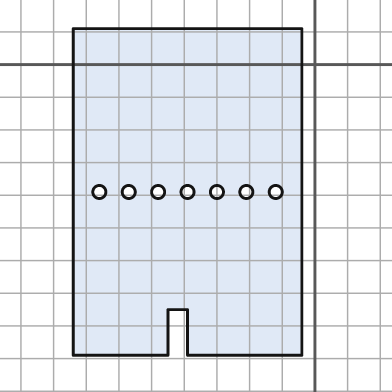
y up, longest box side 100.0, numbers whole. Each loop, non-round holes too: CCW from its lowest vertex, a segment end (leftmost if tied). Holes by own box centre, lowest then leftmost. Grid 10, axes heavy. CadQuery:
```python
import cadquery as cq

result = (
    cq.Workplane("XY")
    .moveTo(-74.0, -89.0)
    .lineTo(-45.0, -89.0)
    .lineTo(-45.0, -75.0)
    .lineTo(-39.0, -75.0)
    .lineTo(-39.0, -89.0)
    .lineTo(-4.0, -89.0)
    .lineTo(-4.0, 11.0)
    .lineTo(-74.0, 11.0)
    .close()
    .moveTo(-66.0, -39.0)
    .circle(2.0)
    .moveTo(-57.0, -39.0)
    .circle(2.0)
    .moveTo(-48.0, -39.0)
    .circle(2.0)
    .moveTo(-39.0, -39.0)
    .circle(2.0)
    .moveTo(-30.0, -39.0)
    .circle(2.0)
    .moveTo(-21.0, -39.0)
    .circle(2.0)
    .moveTo(-12.0, -39.0)
    .circle(2.0)
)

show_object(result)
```